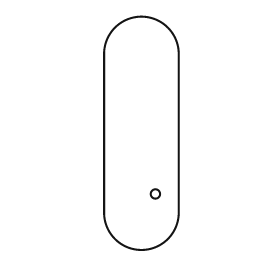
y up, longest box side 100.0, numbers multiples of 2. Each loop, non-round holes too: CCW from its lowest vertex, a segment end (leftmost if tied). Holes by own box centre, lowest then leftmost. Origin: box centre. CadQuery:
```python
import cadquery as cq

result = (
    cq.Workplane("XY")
    .moveTo(-16.0, -34.0)
    .threePointArc((0.0, -50.0), (16.0, -34.0))
    .lineTo(16.0, 34.0)
    .threePointArc((0.0, 50.0), (-16.0, 34.0))
    .close()
    .moveTo(6.0, -26.0)
    .circle(2.0)
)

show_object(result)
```